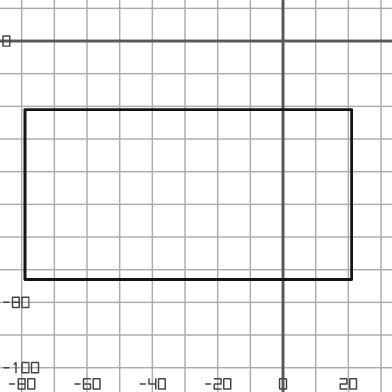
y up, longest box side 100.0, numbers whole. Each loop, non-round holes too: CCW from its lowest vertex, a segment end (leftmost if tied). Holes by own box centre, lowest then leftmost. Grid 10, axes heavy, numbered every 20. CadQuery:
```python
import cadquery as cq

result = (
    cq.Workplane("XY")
    .moveTo(-79.0, -73.0)
    .lineTo(21.0, -73.0)
    .lineTo(21.0, -21.0)
    .lineTo(-79.0, -21.0)
    .close()
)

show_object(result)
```